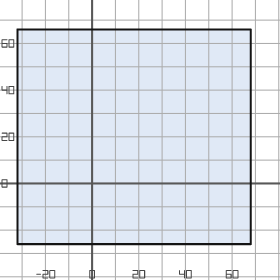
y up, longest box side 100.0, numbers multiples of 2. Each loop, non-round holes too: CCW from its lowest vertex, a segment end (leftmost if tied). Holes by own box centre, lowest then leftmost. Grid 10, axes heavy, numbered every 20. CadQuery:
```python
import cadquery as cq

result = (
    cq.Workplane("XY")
    .moveTo(-32.0, -26.0)
    .lineTo(68.0, -26.0)
    .lineTo(68.0, 66.0)
    .lineTo(-32.0, 66.0)
    .close()
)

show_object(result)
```